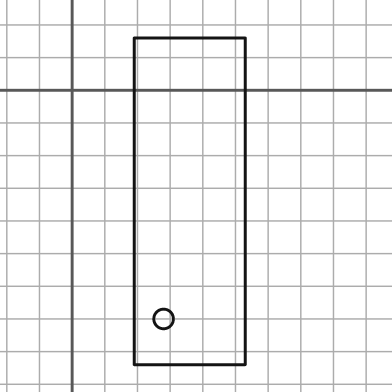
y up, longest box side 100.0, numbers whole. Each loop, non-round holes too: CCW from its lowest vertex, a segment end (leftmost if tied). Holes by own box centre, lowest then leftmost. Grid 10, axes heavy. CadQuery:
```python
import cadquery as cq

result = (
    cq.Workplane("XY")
    .moveTo(19.0, -84.0)
    .lineTo(53.0, -84.0)
    .lineTo(53.0, 16.0)
    .lineTo(19.0, 16.0)
    .close()
    .moveTo(28.0, -70.0)
    .circle(3.0)
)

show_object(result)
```